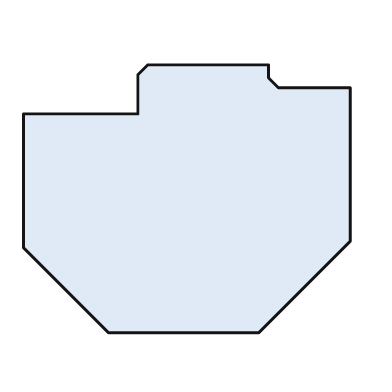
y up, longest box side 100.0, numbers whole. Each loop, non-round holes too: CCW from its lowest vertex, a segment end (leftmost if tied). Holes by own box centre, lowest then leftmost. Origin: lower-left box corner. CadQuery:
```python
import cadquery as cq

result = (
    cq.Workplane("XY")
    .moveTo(26.0, 0.0)
    .lineTo(72.0, 0.0)
    .lineTo(100.0, 28.0)
    .lineTo(100.0, 75.0)
    .lineTo(78.0, 75.0)
    .lineTo(75.0, 78.0)
    .lineTo(75.0, 82.0)
    .lineTo(38.0, 82.0)
    .lineTo(35.0, 79.0)
    .lineTo(35.0, 67.0)
    .lineTo(0.0, 67.0)
    .lineTo(0.0, 26.0)
    .close()
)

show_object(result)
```